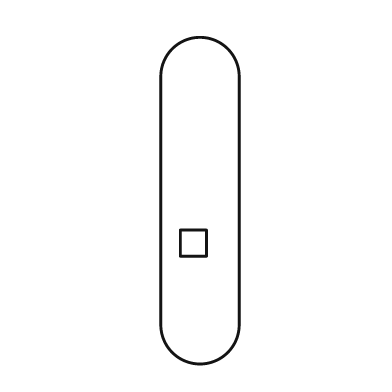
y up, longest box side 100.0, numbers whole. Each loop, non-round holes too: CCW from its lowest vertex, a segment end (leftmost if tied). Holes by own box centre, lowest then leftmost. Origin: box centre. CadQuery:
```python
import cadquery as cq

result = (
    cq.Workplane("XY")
    .moveTo(-12.0, -38.0)
    .threePointArc((0.0, -50.0), (12.0, -38.0))
    .lineTo(12.0, 38.0)
    .threePointArc((0.0, 50.0), (-12.0, 38.0))
    .close()
    .moveTo(-6.0, -17.0)
    .lineTo(2.0, -17.0)
    .lineTo(2.0, -9.0)
    .lineTo(-6.0, -9.0)
    .close()
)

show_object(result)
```